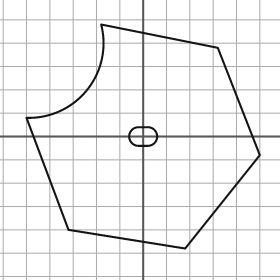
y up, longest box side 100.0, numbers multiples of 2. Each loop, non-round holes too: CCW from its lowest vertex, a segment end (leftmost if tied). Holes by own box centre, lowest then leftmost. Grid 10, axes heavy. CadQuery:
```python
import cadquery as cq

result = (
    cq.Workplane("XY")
    .moveTo(18.0, -48.0)
    .lineTo(50.0, -8.0)
    .lineTo(32.0, 38.0)
    .lineTo(-18.0, 48.0)
    .threePointArc((-24.0, 20.0), (-50.0, 8.0))
    .lineTo(-32.0, -40.0)
    .close()
    .moveTo(-2.0, -4.0)
    .lineTo(2.0, -4.0)
    .threePointArc((6.0, 0.0), (2.0, 4.0))
    .lineTo(-2.0, 4.0)
    .threePointArc((-6.0, 0.0), (-2.0, -4.0))
    .close()
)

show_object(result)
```